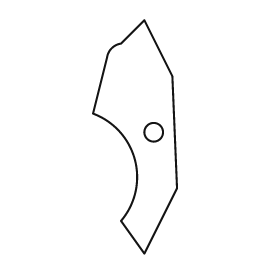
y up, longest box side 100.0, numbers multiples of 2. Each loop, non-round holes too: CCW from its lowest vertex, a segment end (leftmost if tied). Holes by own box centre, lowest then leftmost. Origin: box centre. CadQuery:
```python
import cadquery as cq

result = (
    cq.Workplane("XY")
    .moveTo(4.0, -50.0)
    .lineTo(18.0, -22.0)
    .lineTo(16.0, 26.0)
    .lineTo(4.0, 50.0)
    .lineTo(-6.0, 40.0)
    .threePointArc((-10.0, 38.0), (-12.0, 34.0))
    .lineTo(-18.0, 10.0)
    .threePointArc((0.0, -10.0), (-6.0, -36.0))
    .close()
    .moveTo(8.0, 2.0)
    .circle(4.0)
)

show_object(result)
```